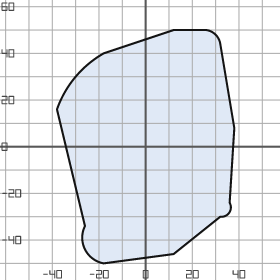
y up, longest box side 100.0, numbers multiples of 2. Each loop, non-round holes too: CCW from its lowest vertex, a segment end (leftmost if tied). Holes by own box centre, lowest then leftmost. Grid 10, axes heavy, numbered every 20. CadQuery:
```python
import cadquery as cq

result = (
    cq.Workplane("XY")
    .moveTo(-18.0, -50.0)
    .lineTo(12.0, -46.0)
    .lineTo(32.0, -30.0)
    .threePointArc((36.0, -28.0), (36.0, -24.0))
    .lineTo(38.0, 8.0)
    .lineTo(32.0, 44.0)
    .threePointArc((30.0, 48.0), (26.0, 50.0))
    .lineTo(12.0, 50.0)
    .lineTo(-18.0, 40.0)
    .threePointArc((-30.0, 30.0), (-38.0, 16.0))
    .lineTo(-26.0, -34.0)
    .threePointArc((-26.0, -44.0), (-18.0, -50.0))
    .close()
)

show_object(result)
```